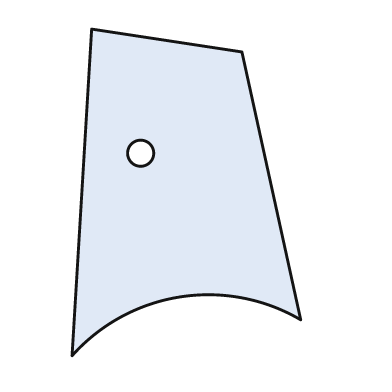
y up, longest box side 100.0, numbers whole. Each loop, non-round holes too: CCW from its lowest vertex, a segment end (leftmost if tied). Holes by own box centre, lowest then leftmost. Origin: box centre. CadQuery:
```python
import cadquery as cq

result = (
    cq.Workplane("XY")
    .moveTo(-35.0, -50.0)
    .threePointArc((-2.0, -32.0), (35.0, -39.0))
    .lineTo(17.0, 43.0)
    .lineTo(-29.0, 50.0)
    .close()
    .moveTo(-14.0, 12.0)
    .circle(4.0)
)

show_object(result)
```